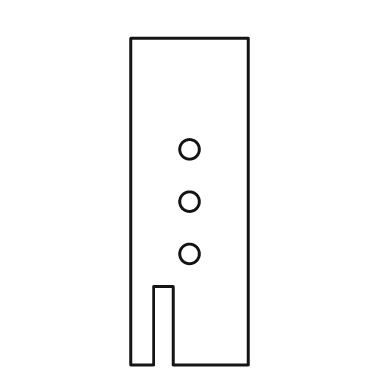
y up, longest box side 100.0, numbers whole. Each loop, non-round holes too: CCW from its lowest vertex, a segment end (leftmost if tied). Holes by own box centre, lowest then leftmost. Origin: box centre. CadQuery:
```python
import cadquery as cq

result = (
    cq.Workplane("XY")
    .moveTo(-18.0, -50.0)
    .lineTo(-11.0, -50.0)
    .lineTo(-11.0, -26.0)
    .lineTo(-5.0, -26.0)
    .lineTo(-5.0, -50.0)
    .lineTo(18.0, -50.0)
    .lineTo(18.0, 50.0)
    .lineTo(-18.0, 50.0)
    .close()
    .moveTo(0.0, -16.0)
    .circle(3.0)
    .moveTo(0.0, 0.0)
    .circle(3.0)
    .moveTo(0.0, 16.0)
    .circle(3.0)
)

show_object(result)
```